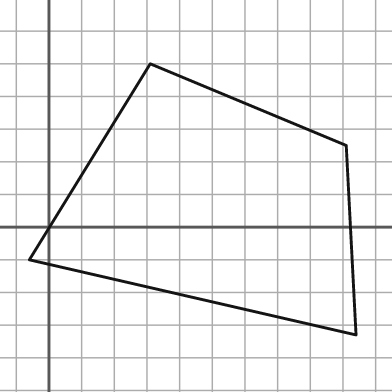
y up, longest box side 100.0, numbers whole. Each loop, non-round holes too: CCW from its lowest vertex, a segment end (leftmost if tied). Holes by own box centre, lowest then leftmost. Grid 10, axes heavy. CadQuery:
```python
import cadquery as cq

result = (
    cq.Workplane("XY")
    .moveTo(94.0, -33.0)
    .lineTo(91.0, 25.0)
    .lineTo(31.0, 50.0)
    .lineTo(-6.0, -10.0)
    .close()
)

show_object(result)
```